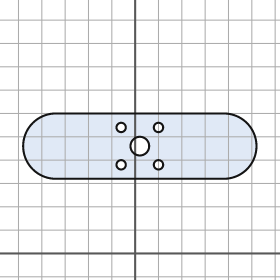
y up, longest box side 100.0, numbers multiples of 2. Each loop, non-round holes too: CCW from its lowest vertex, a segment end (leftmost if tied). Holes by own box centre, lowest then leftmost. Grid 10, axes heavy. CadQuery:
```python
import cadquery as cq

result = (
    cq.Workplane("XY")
    .moveTo(-34.0, 32.0)
    .lineTo(38.0, 32.0)
    .threePointArc((52.0, 46.0), (38.0, 60.0))
    .lineTo(-34.0, 60.0)
    .threePointArc((-48.0, 46.0), (-34.0, 32.0))
    .close()
    .moveTo(-6.0, 38.0)
    .circle(2.0)
    .moveTo(10.0, 38.0)
    .circle(2.0)
    .moveTo(2.0, 46.0)
    .circle(4.0)
    .moveTo(-6.0, 54.0)
    .circle(2.0)
    .moveTo(10.0, 54.0)
    .circle(2.0)
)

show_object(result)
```